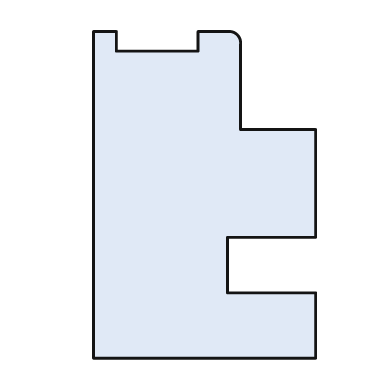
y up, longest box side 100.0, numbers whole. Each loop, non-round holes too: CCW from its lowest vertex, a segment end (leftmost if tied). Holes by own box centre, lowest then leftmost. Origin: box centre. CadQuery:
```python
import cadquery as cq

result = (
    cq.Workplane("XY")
    .moveTo(-34.0, -50.0)
    .lineTo(34.0, -50.0)
    .lineTo(34.0, -30.0)
    .lineTo(7.0, -30.0)
    .lineTo(7.0, -13.0)
    .lineTo(34.0, -13.0)
    .lineTo(34.0, 20.0)
    .lineTo(11.0, 20.0)
    .lineTo(11.0, 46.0)
    .threePointArc((10.0, 49.0), (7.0, 50.0))
    .lineTo(-2.0, 50.0)
    .lineTo(-2.0, 44.0)
    .lineTo(-27.0, 44.0)
    .lineTo(-27.0, 50.0)
    .lineTo(-34.0, 50.0)
    .close()
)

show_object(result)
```